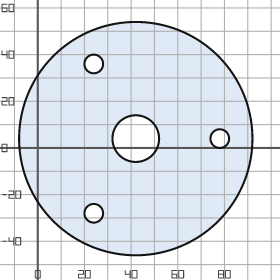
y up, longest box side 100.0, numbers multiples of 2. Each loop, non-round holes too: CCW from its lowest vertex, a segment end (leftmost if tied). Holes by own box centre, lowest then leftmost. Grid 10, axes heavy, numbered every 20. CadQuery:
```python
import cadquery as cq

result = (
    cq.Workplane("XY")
    .moveTo(42.0, 4.0)
    .circle(50.0)
    .moveTo(24.0, -28.0)
    .circle(4.0)
    .moveTo(42.0, 4.0)
    .circle(10.0)
    .moveTo(78.0, 4.0)
    .circle(4.0)
    .moveTo(24.0, 36.0)
    .circle(4.0)
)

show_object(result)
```